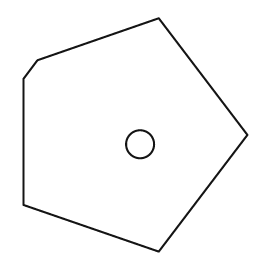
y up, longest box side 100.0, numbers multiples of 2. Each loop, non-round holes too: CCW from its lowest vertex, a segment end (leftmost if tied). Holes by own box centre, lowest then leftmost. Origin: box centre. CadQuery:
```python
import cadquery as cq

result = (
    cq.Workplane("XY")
    .moveTo(10.0, -50.0)
    .lineTo(48.0, 0.0)
    .lineTo(10.0, 50.0)
    .lineTo(-42.0, 32.0)
    .lineTo(-48.0, 24.0)
    .lineTo(-48.0, -30.0)
    .close()
    .moveTo(2.0, -4.0)
    .circle(6.0)
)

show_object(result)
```